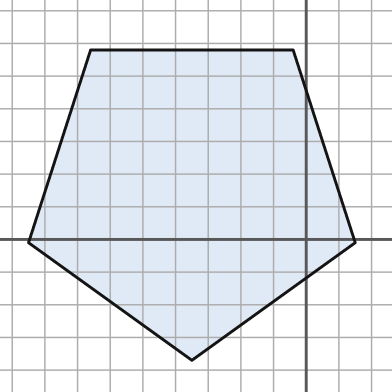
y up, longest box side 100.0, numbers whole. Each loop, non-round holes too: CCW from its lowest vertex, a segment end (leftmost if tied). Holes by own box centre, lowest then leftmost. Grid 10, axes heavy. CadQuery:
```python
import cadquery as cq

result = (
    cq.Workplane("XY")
    .moveTo(-35.0, -37.0)
    .lineTo(15.0, -1.0)
    .lineTo(-4.0, 58.0)
    .lineTo(-66.0, 58.0)
    .lineTo(-85.0, -1.0)
    .close()
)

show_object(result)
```